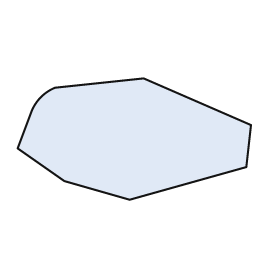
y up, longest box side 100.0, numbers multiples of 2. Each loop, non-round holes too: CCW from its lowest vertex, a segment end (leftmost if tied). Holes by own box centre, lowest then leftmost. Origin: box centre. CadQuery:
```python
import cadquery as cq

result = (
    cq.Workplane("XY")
    .moveTo(-2.0, -26.0)
    .lineTo(48.0, -12.0)
    .lineTo(50.0, 6.0)
    .lineTo(4.0, 26.0)
    .lineTo(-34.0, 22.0)
    .threePointArc((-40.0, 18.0), (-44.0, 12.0))
    .lineTo(-50.0, -4.0)
    .lineTo(-30.0, -18.0)
    .close()
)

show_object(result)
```